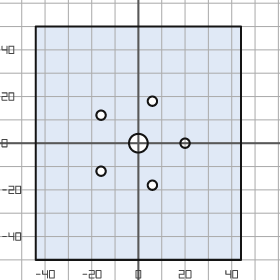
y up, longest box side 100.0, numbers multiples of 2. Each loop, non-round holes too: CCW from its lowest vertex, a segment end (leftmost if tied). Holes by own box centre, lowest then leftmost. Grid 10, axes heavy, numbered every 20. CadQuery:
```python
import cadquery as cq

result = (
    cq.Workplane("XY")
    .moveTo(-44.0, -50.0)
    .lineTo(44.0, -50.0)
    .lineTo(44.0, 50.0)
    .lineTo(-44.0, 50.0)
    .close()
    .moveTo(6.0, -18.0)
    .circle(2.0)
    .moveTo(-16.0, -12.0)
    .circle(2.0)
    .moveTo(0.0, 0.0)
    .circle(4.0)
    .moveTo(20.0, 0.0)
    .circle(2.0)
    .moveTo(-16.0, 12.0)
    .circle(2.0)
    .moveTo(6.0, 18.0)
    .circle(2.0)
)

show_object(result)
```